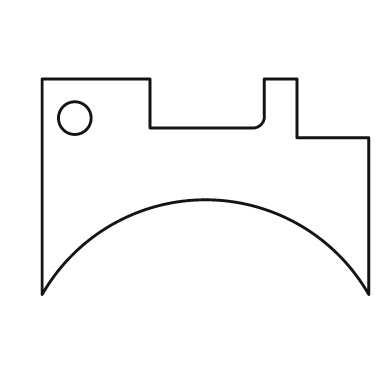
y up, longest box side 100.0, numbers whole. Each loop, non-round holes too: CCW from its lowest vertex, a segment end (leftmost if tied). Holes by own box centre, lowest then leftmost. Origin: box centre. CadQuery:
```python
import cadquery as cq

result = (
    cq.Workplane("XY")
    .moveTo(-50.0, -33.0)
    .threePointArc((0.0, -4.0), (50.0, -33.0))
    .lineTo(50.0, 15.0)
    .lineTo(28.0, 15.0)
    .lineTo(28.0, 33.0)
    .lineTo(18.0, 33.0)
    .lineTo(18.0, 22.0)
    .threePointArc((17.0, 19.0), (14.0, 18.0))
    .lineTo(-17.0, 18.0)
    .lineTo(-17.0, 33.0)
    .lineTo(-50.0, 33.0)
    .close()
    .moveTo(-40.0, 21.0)
    .circle(5.0)
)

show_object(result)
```